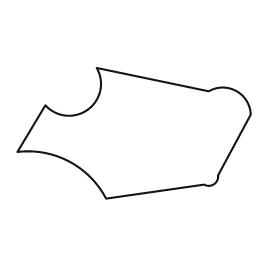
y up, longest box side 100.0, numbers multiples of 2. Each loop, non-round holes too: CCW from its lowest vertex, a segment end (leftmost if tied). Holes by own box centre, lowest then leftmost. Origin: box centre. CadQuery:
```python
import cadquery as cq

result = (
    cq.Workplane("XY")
    .moveTo(-12.0, -28.0)
    .lineTo(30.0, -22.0)
    .threePointArc((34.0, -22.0), (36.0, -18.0))
    .lineTo(50.0, 8.0)
    .threePointArc((44.0, 18.0), (32.0, 18.0))
    .lineTo(-16.0, 28.0)
    .threePointArc((-20.0, 10.0), (-38.0, 12.0))
    .lineTo(-50.0, -8.0)
    .threePointArc((-28.0, -12.0), (-12.0, -28.0))
    .close()
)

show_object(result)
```